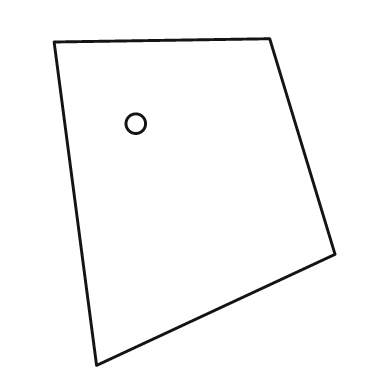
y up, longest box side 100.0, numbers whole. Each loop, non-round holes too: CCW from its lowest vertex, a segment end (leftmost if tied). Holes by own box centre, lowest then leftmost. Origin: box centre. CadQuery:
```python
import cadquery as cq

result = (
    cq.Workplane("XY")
    .moveTo(-30.0, -50.0)
    .lineTo(43.0, -16.0)
    .lineTo(23.0, 50.0)
    .lineTo(-43.0, 49.0)
    .close()
    .moveTo(-18.0, 24.0)
    .circle(3.0)
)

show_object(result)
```